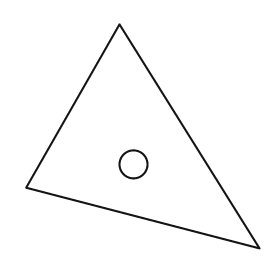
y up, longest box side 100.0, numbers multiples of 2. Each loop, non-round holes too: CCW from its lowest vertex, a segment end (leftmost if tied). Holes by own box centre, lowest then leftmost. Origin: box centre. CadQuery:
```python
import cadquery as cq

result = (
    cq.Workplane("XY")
    .moveTo(50.0, -48.0)
    .lineTo(-10.0, 48.0)
    .lineTo(-50.0, -22.0)
    .close()
    .moveTo(-4.0, -12.0)
    .circle(6.0)
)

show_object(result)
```